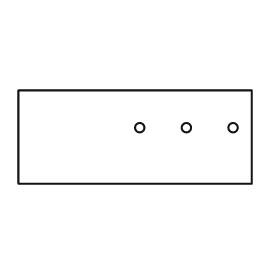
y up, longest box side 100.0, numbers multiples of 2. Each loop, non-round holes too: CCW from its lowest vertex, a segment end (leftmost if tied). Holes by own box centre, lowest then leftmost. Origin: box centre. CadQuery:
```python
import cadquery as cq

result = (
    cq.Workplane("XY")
    .moveTo(-50.0, -20.0)
    .lineTo(50.0, -20.0)
    .lineTo(50.0, 20.0)
    .lineTo(-50.0, 20.0)
    .close()
    .moveTo(2.0, 4.0)
    .circle(2.0)
    .moveTo(22.0, 4.0)
    .circle(2.0)
    .moveTo(42.0, 4.0)
    .circle(2.0)
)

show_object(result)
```